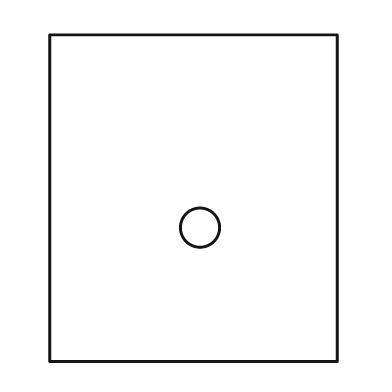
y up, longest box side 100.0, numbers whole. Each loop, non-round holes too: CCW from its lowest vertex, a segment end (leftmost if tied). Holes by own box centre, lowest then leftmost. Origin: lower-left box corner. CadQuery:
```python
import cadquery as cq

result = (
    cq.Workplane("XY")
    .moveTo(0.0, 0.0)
    .lineTo(88.0, 0.0)
    .lineTo(88.0, 100.0)
    .lineTo(0.0, 100.0)
    .close()
    .moveTo(46.0, 41.0)
    .circle(6.0)
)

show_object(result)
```